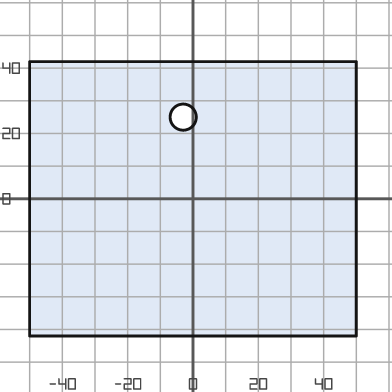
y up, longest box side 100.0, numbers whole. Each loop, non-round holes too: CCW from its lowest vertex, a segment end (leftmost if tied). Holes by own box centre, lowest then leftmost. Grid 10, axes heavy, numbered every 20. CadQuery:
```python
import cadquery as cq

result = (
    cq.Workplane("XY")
    .moveTo(-50.0, -42.0)
    .lineTo(50.0, -42.0)
    .lineTo(50.0, 42.0)
    .lineTo(-50.0, 42.0)
    .close()
    .moveTo(-3.0, 25.0)
    .circle(4.0)
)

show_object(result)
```